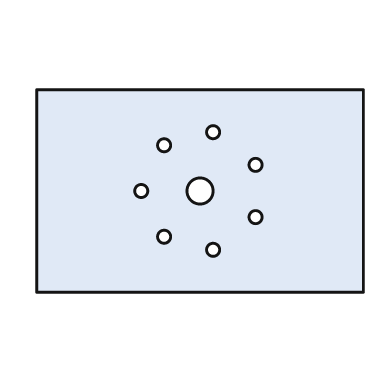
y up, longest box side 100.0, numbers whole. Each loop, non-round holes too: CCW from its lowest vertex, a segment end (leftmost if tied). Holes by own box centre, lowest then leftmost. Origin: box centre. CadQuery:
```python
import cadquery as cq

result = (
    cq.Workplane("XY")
    .moveTo(-50.0, -31.0)
    .lineTo(50.0, -31.0)
    .lineTo(50.0, 31.0)
    .lineTo(-50.0, 31.0)
    .close()
    .moveTo(4.0, -18.0)
    .circle(2.0)
    .moveTo(-11.0, -14.0)
    .circle(2.0)
    .moveTo(17.0, -8.0)
    .circle(2.0)
    .moveTo(-18.0, 0.0)
    .circle(2.0)
    .moveTo(0.0, 0.0)
    .circle(4.0)
    .moveTo(17.0, 8.0)
    .circle(2.0)
    .moveTo(-11.0, 14.0)
    .circle(2.0)
    .moveTo(4.0, 18.0)
    .circle(2.0)
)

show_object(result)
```